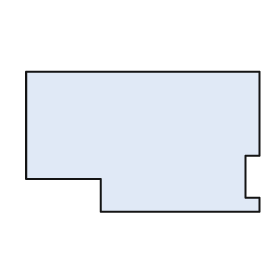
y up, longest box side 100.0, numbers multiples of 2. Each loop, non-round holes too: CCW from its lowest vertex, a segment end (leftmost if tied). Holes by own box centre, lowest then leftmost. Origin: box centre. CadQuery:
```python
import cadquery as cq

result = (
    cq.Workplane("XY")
    .moveTo(-18.0, -30.0)
    .lineTo(50.0, -30.0)
    .lineTo(50.0, -24.0)
    .lineTo(44.0, -24.0)
    .lineTo(44.0, -6.0)
    .lineTo(50.0, -6.0)
    .lineTo(50.0, 30.0)
    .lineTo(-50.0, 30.0)
    .lineTo(-50.0, -16.0)
    .lineTo(-18.0, -16.0)
    .close()
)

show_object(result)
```